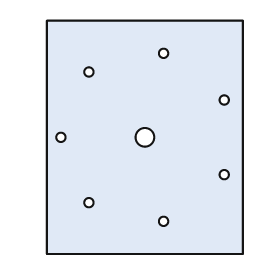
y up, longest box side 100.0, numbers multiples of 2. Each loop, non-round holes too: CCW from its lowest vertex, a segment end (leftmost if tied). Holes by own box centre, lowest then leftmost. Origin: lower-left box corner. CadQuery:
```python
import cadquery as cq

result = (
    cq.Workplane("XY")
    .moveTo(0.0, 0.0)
    .lineTo(84.0, 0.0)
    .lineTo(84.0, 100.0)
    .lineTo(0.0, 100.0)
    .close()
    .moveTo(50.0, 14.0)
    .circle(2.0)
    .moveTo(18.0, 22.0)
    .circle(2.0)
    .moveTo(76.0, 34.0)
    .circle(2.0)
    .moveTo(6.0, 50.0)
    .circle(2.0)
    .moveTo(42.0, 50.0)
    .circle(4.0)
    .moveTo(76.0, 66.0)
    .circle(2.0)
    .moveTo(18.0, 78.0)
    .circle(2.0)
    .moveTo(50.0, 86.0)
    .circle(2.0)
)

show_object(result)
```